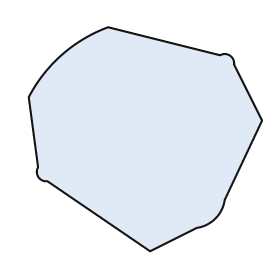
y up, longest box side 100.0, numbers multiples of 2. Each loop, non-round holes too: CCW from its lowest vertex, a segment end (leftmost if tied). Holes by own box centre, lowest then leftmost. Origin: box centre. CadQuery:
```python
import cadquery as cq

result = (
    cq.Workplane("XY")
    .moveTo(2.0, -48.0)
    .lineTo(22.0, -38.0)
    .threePointArc((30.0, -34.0), (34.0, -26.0))
    .lineTo(50.0, 8.0)
    .lineTo(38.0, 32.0)
    .threePointArc((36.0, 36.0), (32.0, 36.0))
    .lineTo(-16.0, 48.0)
    .threePointArc((-36.0, 36.0), (-50.0, 18.0))
    .lineTo(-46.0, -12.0)
    .threePointArc((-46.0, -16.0), (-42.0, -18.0))
    .close()
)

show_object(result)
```